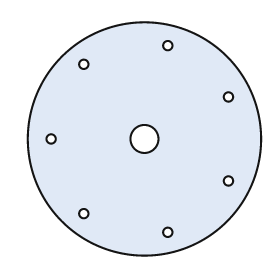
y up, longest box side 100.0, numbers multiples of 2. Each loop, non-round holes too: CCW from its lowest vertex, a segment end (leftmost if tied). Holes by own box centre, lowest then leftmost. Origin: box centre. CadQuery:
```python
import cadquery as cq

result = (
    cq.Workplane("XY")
    .moveTo(0.0, 0.0)
    .circle(50.0)
    .moveTo(10.0, -40.0)
    .circle(2.0)
    .moveTo(-26.0, -32.0)
    .circle(2.0)
    .moveTo(36.0, -18.0)
    .circle(2.0)
    .moveTo(-40.0, 0.0)
    .circle(2.0)
    .moveTo(0.0, 0.0)
    .circle(6.0)
    .moveTo(36.0, 18.0)
    .circle(2.0)
    .moveTo(-26.0, 32.0)
    .circle(2.0)
    .moveTo(10.0, 40.0)
    .circle(2.0)
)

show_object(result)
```